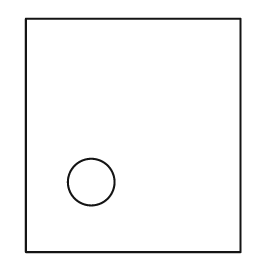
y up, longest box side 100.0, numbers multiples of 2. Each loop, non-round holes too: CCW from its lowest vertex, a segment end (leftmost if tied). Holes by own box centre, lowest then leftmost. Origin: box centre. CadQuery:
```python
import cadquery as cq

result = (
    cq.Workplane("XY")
    .moveTo(-46.0, -50.0)
    .lineTo(46.0, -50.0)
    .lineTo(46.0, 50.0)
    .lineTo(-46.0, 50.0)
    .close()
    .moveTo(-18.0, -20.0)
    .circle(10.0)
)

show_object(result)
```